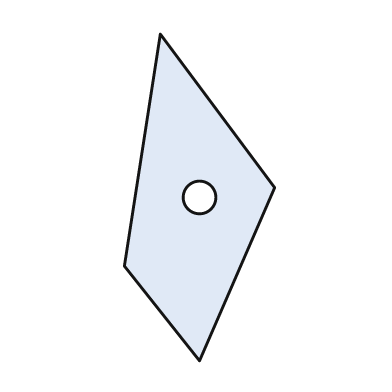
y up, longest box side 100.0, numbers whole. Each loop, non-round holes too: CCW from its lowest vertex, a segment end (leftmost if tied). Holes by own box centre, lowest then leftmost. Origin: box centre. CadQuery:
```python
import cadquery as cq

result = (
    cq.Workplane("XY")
    .moveTo(0.0, -50.0)
    .lineTo(23.0, 3.0)
    .lineTo(-12.0, 50.0)
    .lineTo(-23.0, -21.0)
    .close()
    .moveTo(0.0, 0.0)
    .circle(5.0)
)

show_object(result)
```